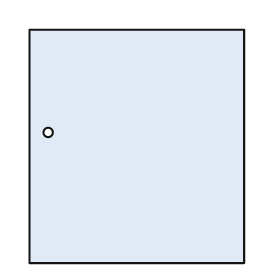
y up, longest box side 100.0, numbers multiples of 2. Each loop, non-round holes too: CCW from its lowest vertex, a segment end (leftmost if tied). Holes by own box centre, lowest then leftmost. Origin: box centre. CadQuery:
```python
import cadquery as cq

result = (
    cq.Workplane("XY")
    .moveTo(-46.0, -50.0)
    .lineTo(46.0, -50.0)
    .lineTo(46.0, 50.0)
    .lineTo(-46.0, 50.0)
    .close()
    .moveTo(-38.0, 6.0)
    .circle(2.0)
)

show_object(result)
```